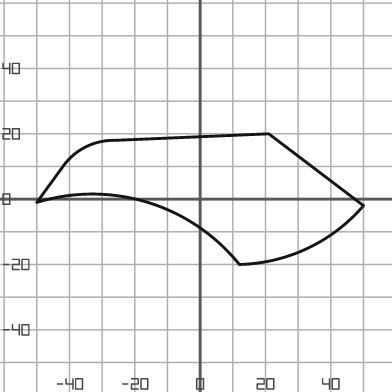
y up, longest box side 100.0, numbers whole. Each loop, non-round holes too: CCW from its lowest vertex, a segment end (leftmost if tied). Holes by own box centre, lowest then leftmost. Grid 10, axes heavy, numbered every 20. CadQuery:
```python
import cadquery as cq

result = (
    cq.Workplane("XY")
    .moveTo(12.0, -20.0)
    .threePointArc((33.0, -15.0), (50.0, -2.0))
    .lineTo(21.0, 20.0)
    .lineTo(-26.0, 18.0)
    .threePointArc((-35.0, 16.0), (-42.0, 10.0))
    .lineTo(-50.0, -1.0)
    .threePointArc((-16.0, -1.0), (12.0, -20.0))
    .close()
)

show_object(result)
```